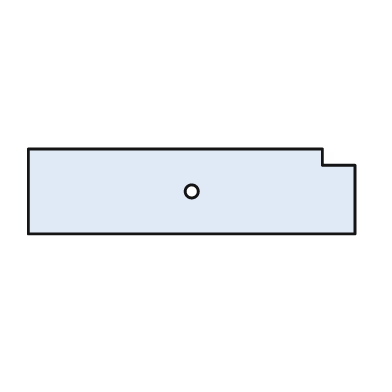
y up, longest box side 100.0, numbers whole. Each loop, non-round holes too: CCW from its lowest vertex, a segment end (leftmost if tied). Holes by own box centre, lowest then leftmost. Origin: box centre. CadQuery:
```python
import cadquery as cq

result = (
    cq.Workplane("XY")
    .moveTo(-50.0, -13.0)
    .lineTo(50.0, -13.0)
    .lineTo(50.0, 8.0)
    .lineTo(40.0, 8.0)
    .lineTo(40.0, 13.0)
    .lineTo(-50.0, 13.0)
    .close()
    .moveTo(0.0, 0.0)
    .circle(2.0)
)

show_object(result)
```